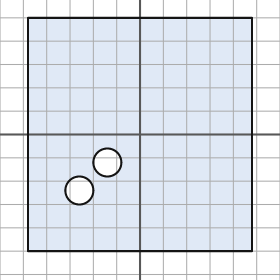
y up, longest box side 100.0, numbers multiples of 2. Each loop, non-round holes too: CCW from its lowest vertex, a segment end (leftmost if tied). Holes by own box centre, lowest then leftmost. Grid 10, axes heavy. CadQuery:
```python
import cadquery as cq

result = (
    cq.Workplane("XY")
    .moveTo(-48.0, -50.0)
    .lineTo(48.0, -50.0)
    .lineTo(48.0, 50.0)
    .lineTo(-48.0, 50.0)
    .close()
    .moveTo(-26.0, -24.0)
    .circle(6.0)
    .moveTo(-14.0, -12.0)
    .circle(6.0)
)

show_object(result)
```